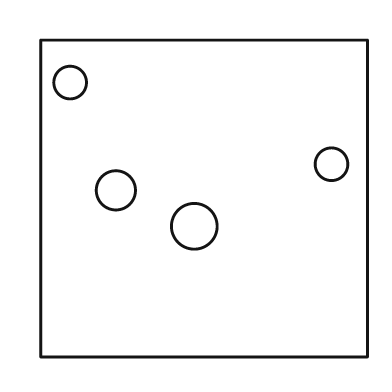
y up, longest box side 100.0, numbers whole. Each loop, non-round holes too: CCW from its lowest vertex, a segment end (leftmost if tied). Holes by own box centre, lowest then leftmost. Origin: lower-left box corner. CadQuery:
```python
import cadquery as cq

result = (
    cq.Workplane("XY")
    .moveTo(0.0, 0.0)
    .lineTo(100.0, 0.0)
    .lineTo(100.0, 97.0)
    .lineTo(0.0, 97.0)
    .close()
    .moveTo(47.0, 40.0)
    .circle(7.0)
    .moveTo(23.0, 51.0)
    .circle(6.0)
    .moveTo(89.0, 59.0)
    .circle(5.0)
    .moveTo(9.0, 84.0)
    .circle(5.0)
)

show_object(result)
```